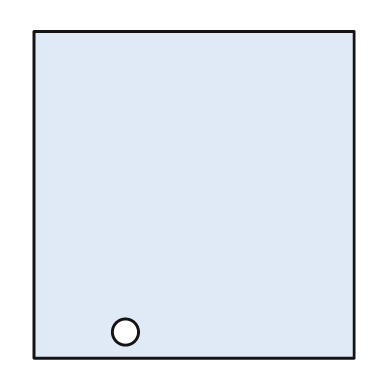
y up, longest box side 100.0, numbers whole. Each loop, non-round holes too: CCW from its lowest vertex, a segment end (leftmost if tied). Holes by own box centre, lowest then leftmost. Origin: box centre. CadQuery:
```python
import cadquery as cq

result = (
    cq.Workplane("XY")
    .moveTo(-49.0, -50.0)
    .lineTo(49.0, -50.0)
    .lineTo(49.0, 50.0)
    .lineTo(-49.0, 50.0)
    .close()
    .moveTo(-21.0, -42.0)
    .circle(4.0)
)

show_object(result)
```